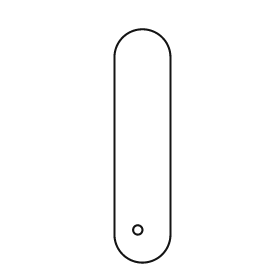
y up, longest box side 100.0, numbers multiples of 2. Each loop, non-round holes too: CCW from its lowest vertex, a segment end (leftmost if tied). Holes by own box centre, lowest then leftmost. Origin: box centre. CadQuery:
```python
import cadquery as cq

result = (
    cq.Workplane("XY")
    .moveTo(-12.0, -38.0)
    .threePointArc((0.0, -50.0), (12.0, -38.0))
    .lineTo(12.0, 38.0)
    .threePointArc((0.0, 50.0), (-12.0, 38.0))
    .close()
    .moveTo(-2.0, -36.0)
    .circle(2.0)
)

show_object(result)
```